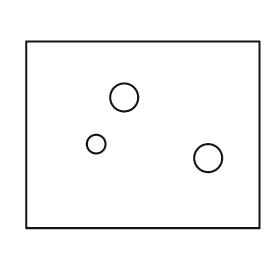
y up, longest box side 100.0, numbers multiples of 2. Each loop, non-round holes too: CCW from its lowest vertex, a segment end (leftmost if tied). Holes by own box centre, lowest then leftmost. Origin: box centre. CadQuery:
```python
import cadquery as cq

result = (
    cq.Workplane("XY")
    .moveTo(-50.0, -40.0)
    .lineTo(50.0, -40.0)
    .lineTo(50.0, 40.0)
    .lineTo(-50.0, 40.0)
    .close()
    .moveTo(28.0, -10.0)
    .circle(6.0)
    .moveTo(-20.0, -4.0)
    .circle(4.0)
    .moveTo(-8.0, 16.0)
    .circle(6.0)
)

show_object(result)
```